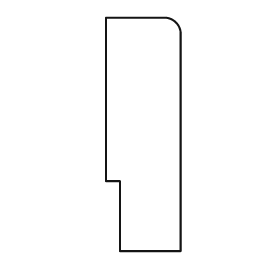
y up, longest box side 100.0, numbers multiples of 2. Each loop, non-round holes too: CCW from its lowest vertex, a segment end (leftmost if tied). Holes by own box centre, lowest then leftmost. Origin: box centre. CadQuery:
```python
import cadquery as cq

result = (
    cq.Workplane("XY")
    .moveTo(-10.0, -50.0)
    .lineTo(16.0, -50.0)
    .lineTo(16.0, 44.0)
    .threePointArc((14.0, 48.0), (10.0, 50.0))
    .lineTo(-16.0, 50.0)
    .lineTo(-16.0, -20.0)
    .lineTo(-10.0, -20.0)
    .close()
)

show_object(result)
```